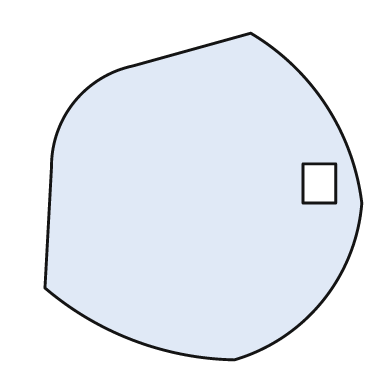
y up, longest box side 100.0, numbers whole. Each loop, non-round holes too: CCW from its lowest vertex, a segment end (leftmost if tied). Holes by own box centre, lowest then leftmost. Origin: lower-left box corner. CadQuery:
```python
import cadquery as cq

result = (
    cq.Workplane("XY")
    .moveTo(58.0, 0.0)
    .threePointArc((85.0, 18.0), (97.0, 48.0))
    .threePointArc((86.0, 78.0), (63.0, 100.0))
    .lineTo(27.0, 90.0)
    .threePointArc((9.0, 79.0), (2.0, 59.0))
    .lineTo(0.0, 22.0)
    .threePointArc((27.0, 6.0), (58.0, 0.0))
    .close()
    .moveTo(79.0, 48.0)
    .lineTo(89.0, 48.0)
    .lineTo(89.0, 60.0)
    .lineTo(79.0, 60.0)
    .close()
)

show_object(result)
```